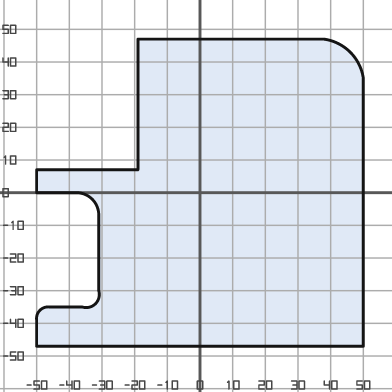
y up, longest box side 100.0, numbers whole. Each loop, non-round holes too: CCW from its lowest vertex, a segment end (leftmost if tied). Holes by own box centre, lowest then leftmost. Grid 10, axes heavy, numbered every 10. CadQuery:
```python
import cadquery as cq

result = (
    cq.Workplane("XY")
    .moveTo(-50.0, -47.0)
    .lineTo(50.0, -47.0)
    .lineTo(50.0, 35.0)
    .threePointArc((46.0, 43.0), (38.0, 47.0))
    .lineTo(-19.0, 47.0)
    .lineTo(-19.0, 7.0)
    .lineTo(-50.0, 7.0)
    .lineTo(-50.0, 0.0)
    .lineTo(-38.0, 0.0)
    .threePointArc((-33.0, -2.0), (-31.0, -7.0))
    .lineTo(-31.0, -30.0)
    .threePointArc((-32.0, -34.0), (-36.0, -35.0))
    .lineTo(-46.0, -35.0)
    .threePointArc((-49.0, -36.0), (-50.0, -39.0))
    .close()
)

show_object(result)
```